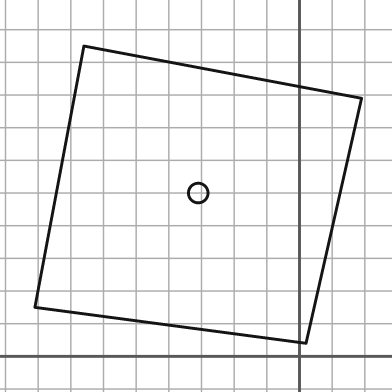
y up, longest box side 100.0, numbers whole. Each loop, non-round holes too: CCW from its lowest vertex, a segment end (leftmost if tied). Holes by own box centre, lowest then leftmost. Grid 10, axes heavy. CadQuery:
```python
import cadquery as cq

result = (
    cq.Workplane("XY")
    .moveTo(2.0, 4.0)
    .lineTo(19.0, 79.0)
    .lineTo(-66.0, 95.0)
    .lineTo(-81.0, 15.0)
    .close()
    .moveTo(-31.0, 50.0)
    .circle(3.0)
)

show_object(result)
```